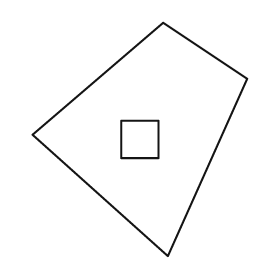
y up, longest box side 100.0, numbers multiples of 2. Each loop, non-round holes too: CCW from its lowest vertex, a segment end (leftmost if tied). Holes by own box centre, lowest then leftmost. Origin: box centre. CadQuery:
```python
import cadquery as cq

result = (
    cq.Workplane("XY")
    .moveTo(12.0, -50.0)
    .lineTo(46.0, 26.0)
    .lineTo(10.0, 50.0)
    .lineTo(-46.0, 2.0)
    .close()
    .moveTo(-8.0, -8.0)
    .lineTo(8.0, -8.0)
    .lineTo(8.0, 8.0)
    .lineTo(-8.0, 8.0)
    .close()
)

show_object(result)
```